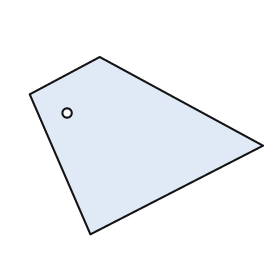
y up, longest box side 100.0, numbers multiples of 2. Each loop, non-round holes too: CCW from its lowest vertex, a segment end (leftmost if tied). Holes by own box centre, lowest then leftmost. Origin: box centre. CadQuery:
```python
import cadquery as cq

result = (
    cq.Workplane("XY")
    .moveTo(-24.0, -38.0)
    .lineTo(50.0, 0.0)
    .lineTo(-20.0, 38.0)
    .lineTo(-50.0, 22.0)
    .close()
    .moveTo(-34.0, 14.0)
    .circle(2.0)
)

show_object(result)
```